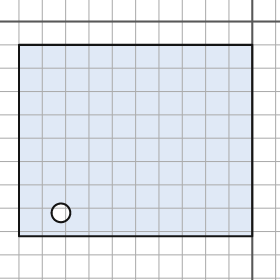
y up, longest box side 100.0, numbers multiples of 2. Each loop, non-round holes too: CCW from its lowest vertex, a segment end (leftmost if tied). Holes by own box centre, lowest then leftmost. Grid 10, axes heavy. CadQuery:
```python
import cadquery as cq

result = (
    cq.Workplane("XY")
    .moveTo(-100.0, -92.0)
    .lineTo(0.0, -92.0)
    .lineTo(0.0, -10.0)
    .lineTo(-100.0, -10.0)
    .close()
    .moveTo(-82.0, -82.0)
    .circle(4.0)
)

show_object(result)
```